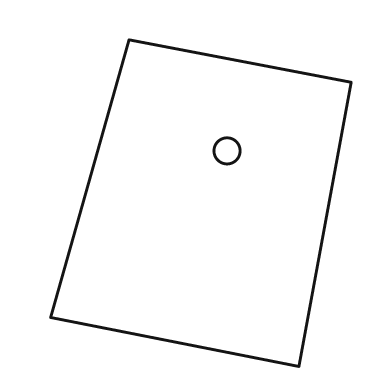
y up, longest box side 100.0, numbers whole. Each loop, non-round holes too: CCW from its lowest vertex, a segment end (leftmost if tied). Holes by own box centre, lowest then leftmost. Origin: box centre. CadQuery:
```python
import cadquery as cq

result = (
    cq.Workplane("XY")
    .moveTo(30.0, -50.0)
    .lineTo(46.0, 37.0)
    .lineTo(-22.0, 50.0)
    .lineTo(-46.0, -35.0)
    .close()
    .moveTo(8.0, 16.0)
    .circle(4.0)
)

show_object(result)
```